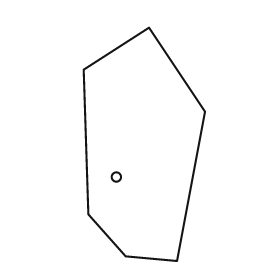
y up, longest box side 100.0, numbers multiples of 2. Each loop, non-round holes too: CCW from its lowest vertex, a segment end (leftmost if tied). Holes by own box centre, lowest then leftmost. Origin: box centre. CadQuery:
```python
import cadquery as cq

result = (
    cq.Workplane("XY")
    .moveTo(14.0, -50.0)
    .lineTo(26.0, 14.0)
    .lineTo(2.0, 50.0)
    .lineTo(-26.0, 32.0)
    .lineTo(-24.0, -30.0)
    .lineTo(-8.0, -48.0)
    .close()
    .moveTo(-12.0, -14.0)
    .circle(2.0)
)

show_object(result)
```